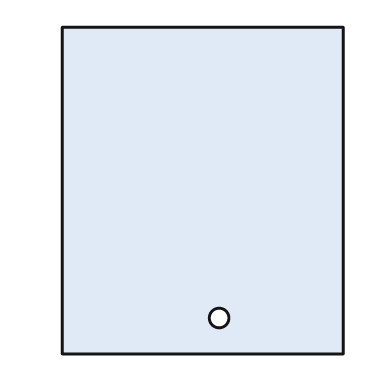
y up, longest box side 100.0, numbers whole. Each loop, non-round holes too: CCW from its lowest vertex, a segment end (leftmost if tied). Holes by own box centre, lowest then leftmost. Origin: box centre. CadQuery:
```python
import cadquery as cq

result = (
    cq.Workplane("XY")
    .moveTo(-43.0, -50.0)
    .lineTo(43.0, -50.0)
    .lineTo(43.0, 50.0)
    .lineTo(-43.0, 50.0)
    .close()
    .moveTo(5.0, -39.0)
    .circle(3.0)
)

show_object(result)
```